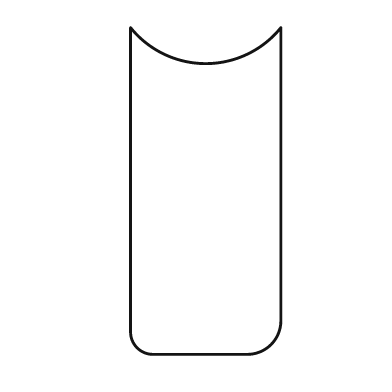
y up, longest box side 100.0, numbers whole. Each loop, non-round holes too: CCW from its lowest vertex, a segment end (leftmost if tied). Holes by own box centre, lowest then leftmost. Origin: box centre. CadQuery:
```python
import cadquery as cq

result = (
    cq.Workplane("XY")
    .moveTo(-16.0, -50.0)
    .lineTo(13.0, -50.0)
    .threePointArc((20.0, -47.0), (23.0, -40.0))
    .lineTo(23.0, 50.0)
    .threePointArc((0.0, 39.0), (-23.0, 50.0))
    .lineTo(-23.0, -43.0)
    .threePointArc((-21.0, -48.0), (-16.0, -50.0))
    .close()
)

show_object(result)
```